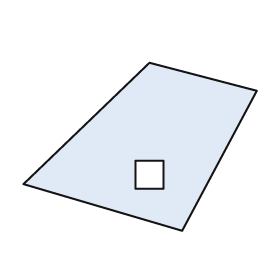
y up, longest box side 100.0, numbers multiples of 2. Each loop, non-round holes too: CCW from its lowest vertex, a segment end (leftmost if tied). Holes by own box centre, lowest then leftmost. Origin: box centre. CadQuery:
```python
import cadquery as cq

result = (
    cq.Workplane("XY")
    .moveTo(18.0, -36.0)
    .lineTo(50.0, 24.0)
    .lineTo(4.0, 36.0)
    .lineTo(-50.0, -16.0)
    .close()
    .moveTo(-2.0, -18.0)
    .lineTo(10.0, -18.0)
    .lineTo(10.0, -6.0)
    .lineTo(-2.0, -6.0)
    .close()
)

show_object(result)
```